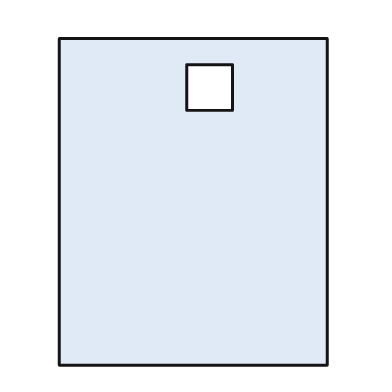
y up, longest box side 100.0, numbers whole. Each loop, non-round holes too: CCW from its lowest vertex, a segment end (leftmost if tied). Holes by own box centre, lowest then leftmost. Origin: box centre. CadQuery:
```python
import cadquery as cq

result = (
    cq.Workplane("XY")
    .moveTo(-41.0, -50.0)
    .lineTo(41.0, -50.0)
    .lineTo(41.0, 50.0)
    .lineTo(-41.0, 50.0)
    .close()
    .moveTo(-2.0, 28.0)
    .lineTo(12.0, 28.0)
    .lineTo(12.0, 42.0)
    .lineTo(-2.0, 42.0)
    .close()
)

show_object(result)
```